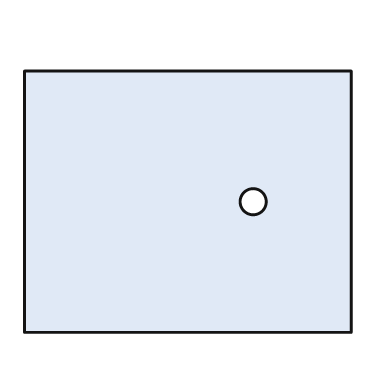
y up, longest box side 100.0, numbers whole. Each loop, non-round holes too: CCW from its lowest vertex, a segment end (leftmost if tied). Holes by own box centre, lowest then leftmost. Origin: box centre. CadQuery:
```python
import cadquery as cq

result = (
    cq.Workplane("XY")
    .moveTo(-50.0, -40.0)
    .lineTo(50.0, -40.0)
    .lineTo(50.0, 40.0)
    .lineTo(-50.0, 40.0)
    .close()
    .moveTo(20.0, 0.0)
    .circle(4.0)
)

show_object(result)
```